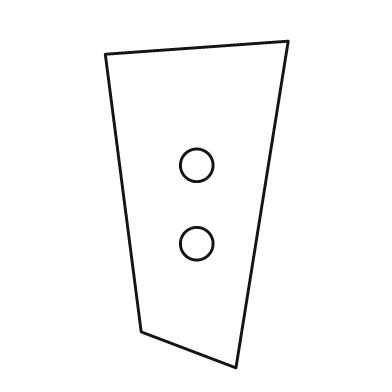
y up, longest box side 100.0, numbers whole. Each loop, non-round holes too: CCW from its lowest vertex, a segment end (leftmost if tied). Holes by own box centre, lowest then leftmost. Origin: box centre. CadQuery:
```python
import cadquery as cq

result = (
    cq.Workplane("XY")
    .moveTo(12.0, -50.0)
    .lineTo(28.0, 50.0)
    .lineTo(-28.0, 46.0)
    .lineTo(-17.0, -39.0)
    .close()
    .moveTo(0.0, -12.0)
    .circle(5.0)
    .moveTo(0.0, 12.0)
    .circle(5.0)
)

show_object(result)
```